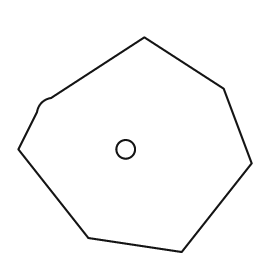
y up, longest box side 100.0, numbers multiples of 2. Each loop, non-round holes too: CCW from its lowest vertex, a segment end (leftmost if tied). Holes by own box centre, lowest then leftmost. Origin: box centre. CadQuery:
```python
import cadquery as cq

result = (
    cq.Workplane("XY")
    .moveTo(20.0, -46.0)
    .lineTo(50.0, -8.0)
    .lineTo(38.0, 24.0)
    .lineTo(4.0, 46.0)
    .lineTo(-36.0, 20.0)
    .threePointArc((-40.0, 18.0), (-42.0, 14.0))
    .lineTo(-50.0, -2.0)
    .lineTo(-20.0, -40.0)
    .close()
    .moveTo(-4.0, -2.0)
    .circle(4.0)
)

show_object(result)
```